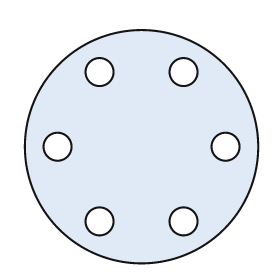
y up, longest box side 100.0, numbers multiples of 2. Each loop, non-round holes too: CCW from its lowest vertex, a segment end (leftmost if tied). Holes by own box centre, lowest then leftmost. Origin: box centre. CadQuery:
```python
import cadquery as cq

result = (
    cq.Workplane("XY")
    .moveTo(0.0, 0.0)
    .circle(50.0)
    .moveTo(-18.0, -32.0)
    .circle(6.0)
    .moveTo(18.0, -32.0)
    .circle(6.0)
    .moveTo(-36.0, 0.0)
    .circle(6.0)
    .moveTo(36.0, 0.0)
    .circle(6.0)
    .moveTo(-18.0, 32.0)
    .circle(6.0)
    .moveTo(18.0, 32.0)
    .circle(6.0)
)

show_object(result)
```